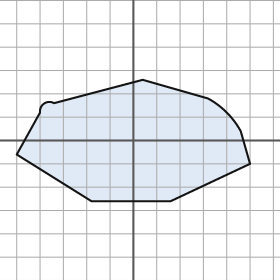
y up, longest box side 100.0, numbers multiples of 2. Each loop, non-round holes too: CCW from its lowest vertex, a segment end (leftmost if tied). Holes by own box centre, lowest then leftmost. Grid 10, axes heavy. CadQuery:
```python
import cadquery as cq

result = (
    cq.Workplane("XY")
    .moveTo(-18.0, -26.0)
    .lineTo(16.0, -26.0)
    .lineTo(50.0, -10.0)
    .lineTo(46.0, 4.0)
    .threePointArc((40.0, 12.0), (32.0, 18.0))
    .lineTo(4.0, 26.0)
    .lineTo(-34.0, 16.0)
    .threePointArc((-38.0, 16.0), (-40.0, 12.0))
    .lineTo(-50.0, -6.0)
    .close()
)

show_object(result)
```